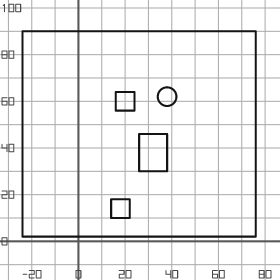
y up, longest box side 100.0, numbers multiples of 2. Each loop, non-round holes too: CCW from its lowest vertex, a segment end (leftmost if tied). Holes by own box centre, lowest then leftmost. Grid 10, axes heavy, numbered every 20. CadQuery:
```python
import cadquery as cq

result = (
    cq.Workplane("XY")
    .moveTo(-24.0, 2.0)
    .lineTo(76.0, 2.0)
    .lineTo(76.0, 90.0)
    .lineTo(-24.0, 90.0)
    .close()
    .moveTo(14.0, 10.0)
    .lineTo(22.0, 10.0)
    .lineTo(22.0, 18.0)
    .lineTo(14.0, 18.0)
    .close()
    .moveTo(26.0, 30.0)
    .lineTo(38.0, 30.0)
    .lineTo(38.0, 46.0)
    .lineTo(26.0, 46.0)
    .close()
    .moveTo(16.0, 56.0)
    .lineTo(24.0, 56.0)
    .lineTo(24.0, 64.0)
    .lineTo(16.0, 64.0)
    .close()
    .moveTo(38.0, 62.0)
    .circle(4.0)
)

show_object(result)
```